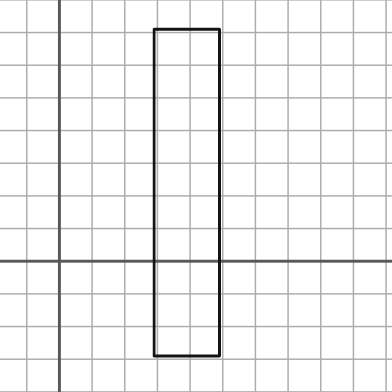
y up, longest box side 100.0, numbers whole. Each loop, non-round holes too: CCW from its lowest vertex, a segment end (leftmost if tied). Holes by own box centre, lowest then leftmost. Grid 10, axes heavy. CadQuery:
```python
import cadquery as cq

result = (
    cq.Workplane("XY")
    .moveTo(29.0, -29.0)
    .lineTo(49.0, -29.0)
    .lineTo(49.0, 71.0)
    .lineTo(29.0, 71.0)
    .close()
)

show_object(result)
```